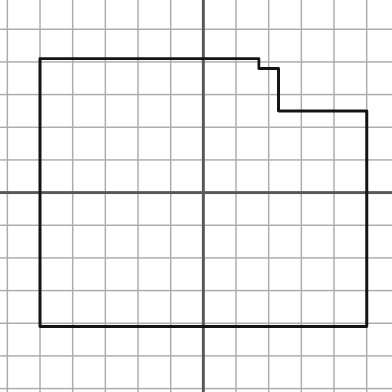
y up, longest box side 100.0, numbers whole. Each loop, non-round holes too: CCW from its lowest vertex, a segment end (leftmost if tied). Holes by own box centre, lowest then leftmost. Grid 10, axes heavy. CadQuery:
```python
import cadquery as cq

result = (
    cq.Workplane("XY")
    .moveTo(-50.0, -41.0)
    .lineTo(50.0, -41.0)
    .lineTo(50.0, 25.0)
    .lineTo(23.0, 25.0)
    .lineTo(23.0, 38.0)
    .lineTo(17.0, 38.0)
    .lineTo(17.0, 41.0)
    .lineTo(-50.0, 41.0)
    .close()
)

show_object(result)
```